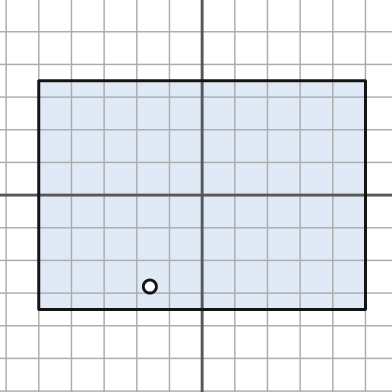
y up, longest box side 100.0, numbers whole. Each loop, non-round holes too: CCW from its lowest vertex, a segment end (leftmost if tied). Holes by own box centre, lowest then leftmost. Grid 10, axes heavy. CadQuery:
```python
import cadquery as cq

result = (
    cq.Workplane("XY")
    .moveTo(-50.0, -35.0)
    .lineTo(50.0, -35.0)
    .lineTo(50.0, 35.0)
    .lineTo(-50.0, 35.0)
    .close()
    .moveTo(-16.0, -28.0)
    .circle(2.0)
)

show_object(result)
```